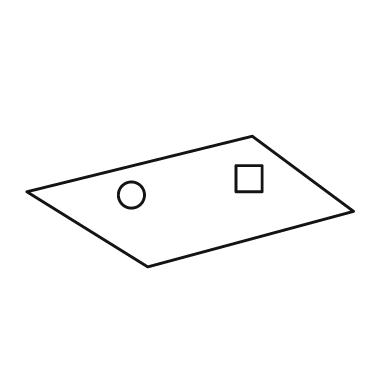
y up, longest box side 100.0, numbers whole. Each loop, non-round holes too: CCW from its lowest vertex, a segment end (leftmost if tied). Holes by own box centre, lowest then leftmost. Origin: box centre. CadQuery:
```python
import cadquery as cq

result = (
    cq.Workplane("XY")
    .moveTo(-13.0, -20.0)
    .lineTo(50.0, -3.0)
    .lineTo(19.0, 20.0)
    .lineTo(-50.0, 3.0)
    .close()
    .moveTo(-18.0, 2.0)
    .circle(4.0)
    .moveTo(14.0, 3.0)
    .lineTo(22.0, 3.0)
    .lineTo(22.0, 11.0)
    .lineTo(14.0, 11.0)
    .close()
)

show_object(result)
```